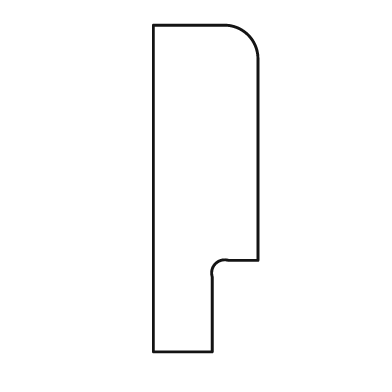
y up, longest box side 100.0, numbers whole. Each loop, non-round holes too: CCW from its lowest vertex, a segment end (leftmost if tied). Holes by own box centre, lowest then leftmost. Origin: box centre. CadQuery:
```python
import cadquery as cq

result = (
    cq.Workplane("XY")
    .moveTo(-16.0, -50.0)
    .lineTo(2.0, -50.0)
    .lineTo(2.0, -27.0)
    .threePointArc((3.0, -23.0), (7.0, -22.0))
    .lineTo(16.0, -22.0)
    .lineTo(16.0, 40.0)
    .threePointArc((13.0, 47.0), (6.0, 50.0))
    .lineTo(-16.0, 50.0)
    .close()
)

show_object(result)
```